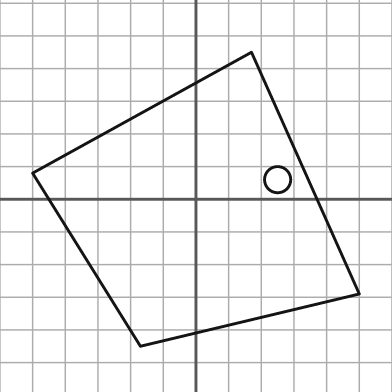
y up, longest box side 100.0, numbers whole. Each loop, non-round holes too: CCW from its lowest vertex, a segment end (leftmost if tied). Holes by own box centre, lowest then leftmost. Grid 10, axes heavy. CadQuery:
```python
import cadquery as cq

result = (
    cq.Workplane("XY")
    .moveTo(-17.0, -45.0)
    .lineTo(50.0, -29.0)
    .lineTo(17.0, 45.0)
    .lineTo(-50.0, 8.0)
    .close()
    .moveTo(25.0, 6.0)
    .circle(4.0)
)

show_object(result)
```